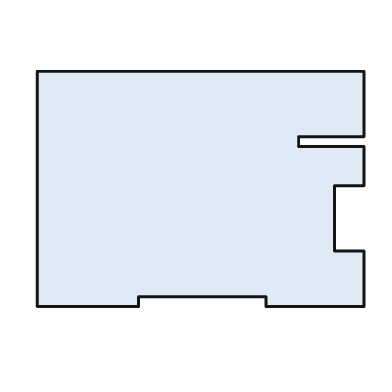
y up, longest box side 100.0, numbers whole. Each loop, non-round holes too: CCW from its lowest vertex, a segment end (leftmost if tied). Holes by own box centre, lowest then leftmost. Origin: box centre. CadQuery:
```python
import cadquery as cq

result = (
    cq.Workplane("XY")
    .moveTo(-50.0, -36.0)
    .lineTo(-19.0, -36.0)
    .lineTo(-19.0, -33.0)
    .lineTo(20.0, -33.0)
    .lineTo(20.0, -36.0)
    .lineTo(50.0, -36.0)
    .lineTo(50.0, -19.0)
    .lineTo(41.0, -19.0)
    .lineTo(41.0, 1.0)
    .lineTo(50.0, 1.0)
    .lineTo(50.0, 13.0)
    .lineTo(30.0, 13.0)
    .lineTo(30.0, 16.0)
    .lineTo(50.0, 16.0)
    .lineTo(50.0, 36.0)
    .lineTo(-50.0, 36.0)
    .close()
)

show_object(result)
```